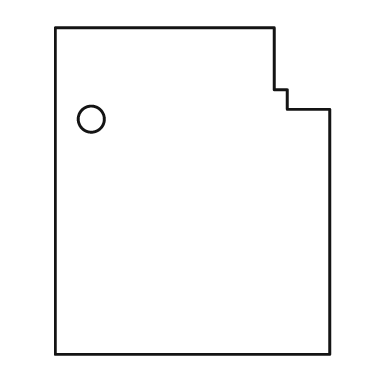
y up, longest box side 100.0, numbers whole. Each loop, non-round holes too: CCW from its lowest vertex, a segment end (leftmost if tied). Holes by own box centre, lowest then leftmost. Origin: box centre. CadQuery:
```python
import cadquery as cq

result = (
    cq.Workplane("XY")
    .moveTo(-42.0, -50.0)
    .lineTo(42.0, -50.0)
    .lineTo(42.0, 25.0)
    .lineTo(29.0, 25.0)
    .lineTo(29.0, 31.0)
    .lineTo(25.0, 31.0)
    .lineTo(25.0, 50.0)
    .lineTo(-42.0, 50.0)
    .close()
    .moveTo(-31.0, 22.0)
    .circle(4.0)
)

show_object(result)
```